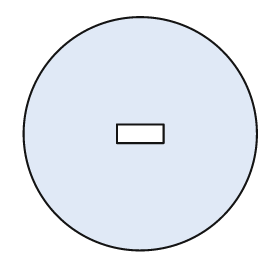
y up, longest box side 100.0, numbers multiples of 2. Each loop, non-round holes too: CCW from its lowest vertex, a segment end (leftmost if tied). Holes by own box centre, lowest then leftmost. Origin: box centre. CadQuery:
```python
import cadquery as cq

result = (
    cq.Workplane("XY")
    .moveTo(0.0, 0.0)
    .circle(50.0)
    .moveTo(-10.0, -4.0)
    .lineTo(10.0, -4.0)
    .lineTo(10.0, 4.0)
    .lineTo(-10.0, 4.0)
    .close()
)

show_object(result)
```